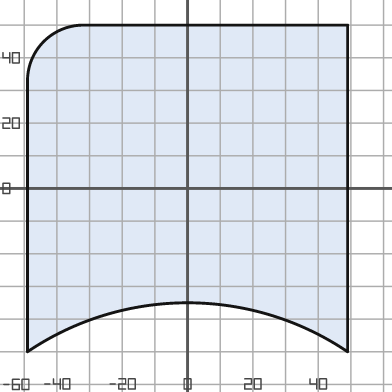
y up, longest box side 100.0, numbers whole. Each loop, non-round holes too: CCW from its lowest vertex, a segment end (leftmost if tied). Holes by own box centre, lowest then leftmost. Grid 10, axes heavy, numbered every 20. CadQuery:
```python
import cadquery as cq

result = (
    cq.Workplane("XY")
    .moveTo(-49.0, -50.0)
    .threePointArc((0.0, -35.0), (49.0, -50.0))
    .lineTo(49.0, 50.0)
    .lineTo(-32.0, 50.0)
    .threePointArc((-44.0, 45.0), (-49.0, 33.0))
    .close()
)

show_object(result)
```